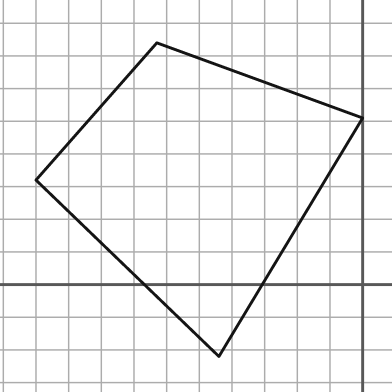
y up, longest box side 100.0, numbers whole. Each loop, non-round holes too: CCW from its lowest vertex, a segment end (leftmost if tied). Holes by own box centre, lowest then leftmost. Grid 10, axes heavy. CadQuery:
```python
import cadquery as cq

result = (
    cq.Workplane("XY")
    .moveTo(-44.0, -22.0)
    .lineTo(0.0, 51.0)
    .lineTo(-63.0, 74.0)
    .lineTo(-100.0, 32.0)
    .close()
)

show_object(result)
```